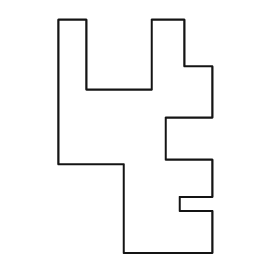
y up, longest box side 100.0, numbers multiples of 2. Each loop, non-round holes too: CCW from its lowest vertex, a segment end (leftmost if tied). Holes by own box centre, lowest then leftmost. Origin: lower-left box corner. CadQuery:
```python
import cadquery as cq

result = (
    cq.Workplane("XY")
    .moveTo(28.0, 0.0)
    .lineTo(66.0, 0.0)
    .lineTo(66.0, 18.0)
    .lineTo(52.0, 18.0)
    .lineTo(52.0, 24.0)
    .lineTo(66.0, 24.0)
    .lineTo(66.0, 40.0)
    .lineTo(46.0, 40.0)
    .lineTo(46.0, 58.0)
    .lineTo(66.0, 58.0)
    .lineTo(66.0, 80.0)
    .lineTo(54.0, 80.0)
    .lineTo(54.0, 100.0)
    .lineTo(40.0, 100.0)
    .lineTo(40.0, 70.0)
    .lineTo(12.0, 70.0)
    .lineTo(12.0, 100.0)
    .lineTo(0.0, 100.0)
    .lineTo(0.0, 38.0)
    .lineTo(28.0, 38.0)
    .close()
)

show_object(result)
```